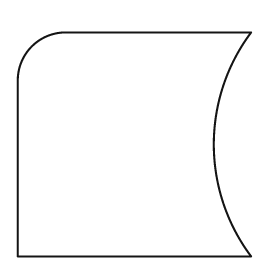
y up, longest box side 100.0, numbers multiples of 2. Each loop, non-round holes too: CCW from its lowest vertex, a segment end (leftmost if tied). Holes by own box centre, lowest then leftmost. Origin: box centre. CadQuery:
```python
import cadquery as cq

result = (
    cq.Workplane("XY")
    .moveTo(-50.0, -48.0)
    .lineTo(50.0, -48.0)
    .threePointArc((34.0, 0.0), (50.0, 48.0))
    .lineTo(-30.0, 48.0)
    .threePointArc((-44.0, 42.0), (-50.0, 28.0))
    .close()
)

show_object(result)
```